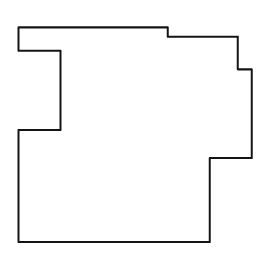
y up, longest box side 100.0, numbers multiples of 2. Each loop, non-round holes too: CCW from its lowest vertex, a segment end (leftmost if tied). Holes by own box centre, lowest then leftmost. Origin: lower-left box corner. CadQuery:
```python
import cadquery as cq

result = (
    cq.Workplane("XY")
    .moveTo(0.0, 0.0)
    .lineTo(82.0, 0.0)
    .lineTo(82.0, 36.0)
    .lineTo(100.0, 36.0)
    .lineTo(100.0, 74.0)
    .lineTo(94.0, 74.0)
    .lineTo(94.0, 88.0)
    .lineTo(64.0, 88.0)
    .lineTo(64.0, 92.0)
    .lineTo(0.0, 92.0)
    .lineTo(0.0, 82.0)
    .lineTo(18.0, 82.0)
    .lineTo(18.0, 48.0)
    .lineTo(0.0, 48.0)
    .close()
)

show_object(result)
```